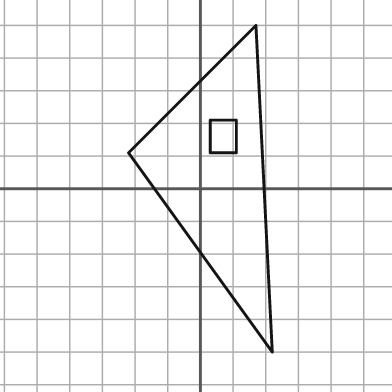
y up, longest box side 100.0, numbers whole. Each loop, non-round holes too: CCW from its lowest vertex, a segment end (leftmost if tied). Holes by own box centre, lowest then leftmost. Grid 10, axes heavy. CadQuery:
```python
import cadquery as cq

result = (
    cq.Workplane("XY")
    .moveTo(22.0, -50.0)
    .lineTo(17.0, 50.0)
    .lineTo(-22.0, 11.0)
    .close()
    .moveTo(3.0, 11.0)
    .lineTo(11.0, 11.0)
    .lineTo(11.0, 21.0)
    .lineTo(3.0, 21.0)
    .close()
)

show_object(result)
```